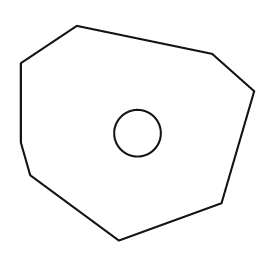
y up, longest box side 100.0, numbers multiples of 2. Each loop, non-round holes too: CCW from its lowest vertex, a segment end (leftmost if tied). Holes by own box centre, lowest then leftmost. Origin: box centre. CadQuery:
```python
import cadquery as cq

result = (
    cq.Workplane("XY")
    .moveTo(-8.0, -46.0)
    .lineTo(36.0, -30.0)
    .lineTo(50.0, 18.0)
    .lineTo(32.0, 34.0)
    .lineTo(-26.0, 46.0)
    .lineTo(-50.0, 30.0)
    .lineTo(-50.0, -4.0)
    .lineTo(-46.0, -18.0)
    .close()
    .moveTo(0.0, 0.0)
    .circle(10.0)
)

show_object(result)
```